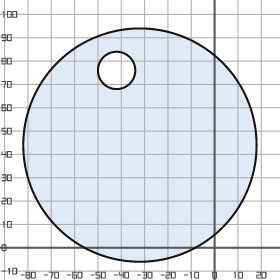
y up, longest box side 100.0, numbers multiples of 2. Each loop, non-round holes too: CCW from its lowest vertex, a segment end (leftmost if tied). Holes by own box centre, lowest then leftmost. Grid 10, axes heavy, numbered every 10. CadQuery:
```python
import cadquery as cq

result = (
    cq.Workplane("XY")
    .moveTo(-32.0, 44.0)
    .circle(50.0)
    .moveTo(-42.0, 76.0)
    .circle(8.0)
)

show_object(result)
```